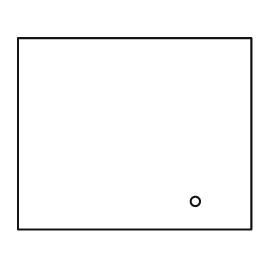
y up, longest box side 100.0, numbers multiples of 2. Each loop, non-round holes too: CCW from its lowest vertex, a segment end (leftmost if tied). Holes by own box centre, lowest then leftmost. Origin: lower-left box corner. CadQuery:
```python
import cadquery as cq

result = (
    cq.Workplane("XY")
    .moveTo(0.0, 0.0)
    .lineTo(100.0, 0.0)
    .lineTo(100.0, 82.0)
    .lineTo(0.0, 82.0)
    .close()
    .moveTo(76.0, 12.0)
    .circle(2.0)
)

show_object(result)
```